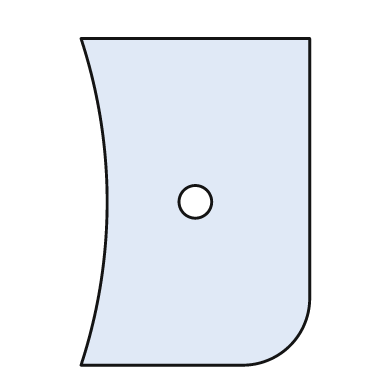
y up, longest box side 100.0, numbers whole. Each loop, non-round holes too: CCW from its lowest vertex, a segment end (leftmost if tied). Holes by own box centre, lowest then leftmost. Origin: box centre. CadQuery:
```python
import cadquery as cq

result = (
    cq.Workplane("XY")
    .moveTo(-35.0, -50.0)
    .lineTo(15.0, -50.0)
    .threePointArc((29.0, -44.0), (35.0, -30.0))
    .lineTo(35.0, 50.0)
    .lineTo(-35.0, 50.0)
    .threePointArc((-27.0, 0.0), (-35.0, -50.0))
    .close()
    .moveTo(0.0, 0.0)
    .circle(5.0)
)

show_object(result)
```